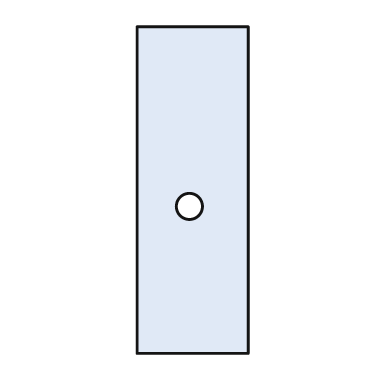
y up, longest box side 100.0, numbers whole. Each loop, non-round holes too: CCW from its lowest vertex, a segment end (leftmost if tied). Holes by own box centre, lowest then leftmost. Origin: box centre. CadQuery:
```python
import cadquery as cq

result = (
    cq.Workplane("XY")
    .moveTo(-17.0, -50.0)
    .lineTo(17.0, -50.0)
    .lineTo(17.0, 50.0)
    .lineTo(-17.0, 50.0)
    .close()
    .moveTo(-1.0, -5.0)
    .circle(4.0)
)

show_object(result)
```